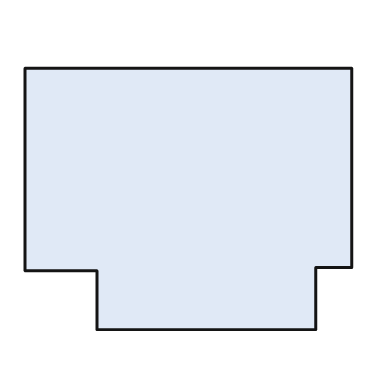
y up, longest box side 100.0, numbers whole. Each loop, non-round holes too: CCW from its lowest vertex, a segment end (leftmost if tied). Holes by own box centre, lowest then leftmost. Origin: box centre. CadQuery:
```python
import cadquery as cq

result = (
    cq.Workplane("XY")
    .moveTo(-28.0, -40.0)
    .lineTo(39.0, -40.0)
    .lineTo(39.0, -21.0)
    .lineTo(50.0, -21.0)
    .lineTo(50.0, 40.0)
    .lineTo(-50.0, 40.0)
    .lineTo(-50.0, -22.0)
    .lineTo(-28.0, -22.0)
    .close()
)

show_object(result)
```